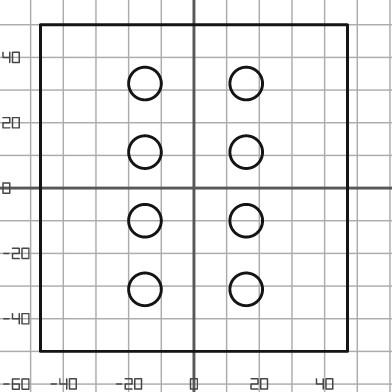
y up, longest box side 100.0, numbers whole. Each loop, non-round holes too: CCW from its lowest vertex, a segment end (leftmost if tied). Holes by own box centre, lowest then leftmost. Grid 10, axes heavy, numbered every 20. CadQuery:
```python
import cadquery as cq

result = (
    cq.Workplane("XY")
    .moveTo(-47.0, -50.0)
    .lineTo(47.0, -50.0)
    .lineTo(47.0, 50.0)
    .lineTo(-47.0, 50.0)
    .close()
    .moveTo(-15.0, -31.0)
    .circle(5.0)
    .moveTo(16.0, -31.0)
    .circle(5.0)
    .moveTo(-15.0, -10.0)
    .circle(5.0)
    .moveTo(16.0, -10.0)
    .circle(5.0)
    .moveTo(-15.0, 11.0)
    .circle(5.0)
    .moveTo(16.0, 11.0)
    .circle(5.0)
    .moveTo(-15.0, 32.0)
    .circle(5.0)
    .moveTo(16.0, 32.0)
    .circle(5.0)
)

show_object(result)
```